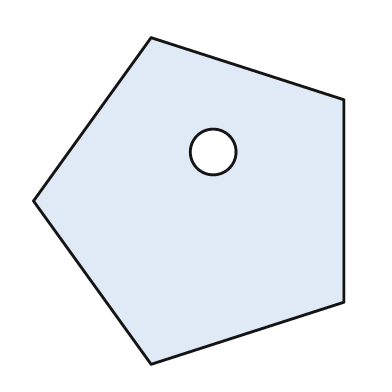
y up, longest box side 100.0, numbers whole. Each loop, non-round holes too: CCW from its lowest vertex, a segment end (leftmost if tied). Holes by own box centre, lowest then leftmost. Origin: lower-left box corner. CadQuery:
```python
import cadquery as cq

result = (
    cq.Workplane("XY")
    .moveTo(36.0, 0.0)
    .lineTo(95.0, 19.0)
    .lineTo(95.0, 81.0)
    .lineTo(36.0, 100.0)
    .lineTo(0.0, 50.0)
    .close()
    .moveTo(55.0, 65.0)
    .circle(7.0)
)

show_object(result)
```